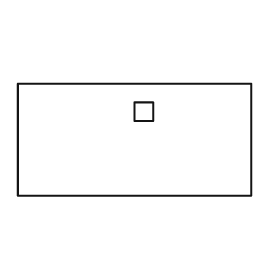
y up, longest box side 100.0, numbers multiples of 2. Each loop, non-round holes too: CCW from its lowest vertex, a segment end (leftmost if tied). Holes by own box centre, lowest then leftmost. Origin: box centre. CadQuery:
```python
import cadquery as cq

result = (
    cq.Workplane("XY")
    .moveTo(-50.0, -24.0)
    .lineTo(50.0, -24.0)
    .lineTo(50.0, 24.0)
    .lineTo(-50.0, 24.0)
    .close()
    .moveTo(0.0, 8.0)
    .lineTo(8.0, 8.0)
    .lineTo(8.0, 16.0)
    .lineTo(0.0, 16.0)
    .close()
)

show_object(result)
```